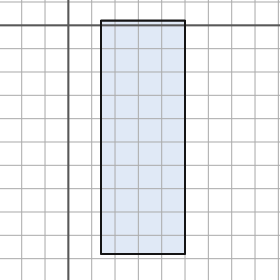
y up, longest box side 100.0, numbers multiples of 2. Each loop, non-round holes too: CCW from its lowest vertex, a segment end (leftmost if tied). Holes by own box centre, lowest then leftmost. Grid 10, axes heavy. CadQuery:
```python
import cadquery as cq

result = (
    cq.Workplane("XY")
    .moveTo(14.0, -98.0)
    .lineTo(50.0, -98.0)
    .lineTo(50.0, 2.0)
    .lineTo(14.0, 2.0)
    .close()
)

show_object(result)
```